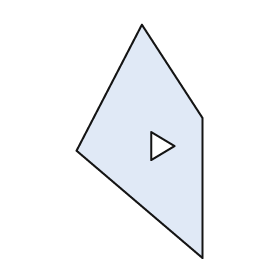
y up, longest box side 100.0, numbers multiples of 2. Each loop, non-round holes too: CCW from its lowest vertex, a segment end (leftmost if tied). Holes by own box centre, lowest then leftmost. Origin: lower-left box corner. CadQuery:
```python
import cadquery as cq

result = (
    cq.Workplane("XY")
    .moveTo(54.0, 0.0)
    .lineTo(54.0, 60.0)
    .lineTo(28.0, 100.0)
    .lineTo(0.0, 46.0)
    .close()
    .moveTo(32.0, 42.0)
    .lineTo(42.0, 48.0)
    .lineTo(32.0, 54.0)
    .close()
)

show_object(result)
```